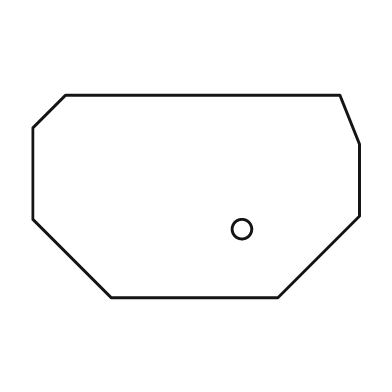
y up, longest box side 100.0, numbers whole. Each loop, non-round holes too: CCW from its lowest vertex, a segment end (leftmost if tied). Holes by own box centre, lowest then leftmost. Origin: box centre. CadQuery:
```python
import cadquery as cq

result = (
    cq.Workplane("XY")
    .moveTo(-26.0, -31.0)
    .lineTo(25.0, -31.0)
    .lineTo(50.0, -6.0)
    .lineTo(50.0, 16.0)
    .lineTo(44.0, 31.0)
    .lineTo(-40.0, 31.0)
    .lineTo(-50.0, 21.0)
    .lineTo(-50.0, -7.0)
    .close()
    .moveTo(14.0, -10.0)
    .circle(3.0)
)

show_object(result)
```